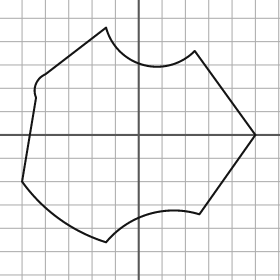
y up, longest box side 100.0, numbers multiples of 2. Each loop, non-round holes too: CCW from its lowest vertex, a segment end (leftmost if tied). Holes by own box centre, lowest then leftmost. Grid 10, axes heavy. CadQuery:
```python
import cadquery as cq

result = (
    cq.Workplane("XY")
    .moveTo(-14.0, -46.0)
    .threePointArc((4.0, -34.0), (26.0, -34.0))
    .lineTo(50.0, 0.0)
    .lineTo(24.0, 36.0)
    .threePointArc((2.0, 30.0), (-14.0, 46.0))
    .lineTo(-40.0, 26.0)
    .threePointArc((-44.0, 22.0), (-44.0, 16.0))
    .lineTo(-50.0, -20.0)
    .threePointArc((-34.0, -36.0), (-14.0, -46.0))
    .close()
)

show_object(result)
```